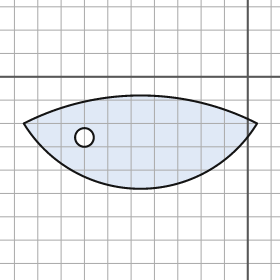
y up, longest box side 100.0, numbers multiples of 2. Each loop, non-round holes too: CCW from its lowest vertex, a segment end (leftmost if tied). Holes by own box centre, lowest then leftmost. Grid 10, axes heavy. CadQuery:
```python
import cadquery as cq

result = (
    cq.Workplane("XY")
    .moveTo(-96.0, -20.0)
    .threePointArc((-46.0, -48.0), (4.0, -20.0))
    .threePointArc((-46.0, -8.0), (-96.0, -20.0))
    .close()
    .moveTo(-70.0, -26.0)
    .circle(4.0)
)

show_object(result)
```